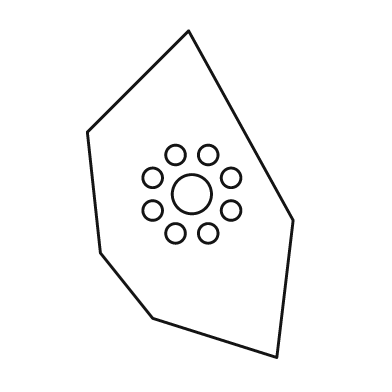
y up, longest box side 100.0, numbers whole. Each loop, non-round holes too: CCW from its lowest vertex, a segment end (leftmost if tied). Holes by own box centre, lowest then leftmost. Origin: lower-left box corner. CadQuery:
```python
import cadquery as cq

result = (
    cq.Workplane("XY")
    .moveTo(58.0, 0.0)
    .lineTo(63.0, 42.0)
    .lineTo(31.0, 100.0)
    .lineTo(0.0, 69.0)
    .lineTo(4.0, 32.0)
    .lineTo(20.0, 12.0)
    .close()
    .moveTo(27.0, 38.0)
    .circle(3.0)
    .moveTo(37.0, 38.0)
    .circle(3.0)
    .moveTo(20.0, 45.0)
    .circle(3.0)
    .moveTo(44.0, 45.0)
    .circle(3.0)
    .moveTo(32.0, 50.0)
    .circle(6.0)
    .moveTo(20.0, 55.0)
    .circle(3.0)
    .moveTo(44.0, 55.0)
    .circle(3.0)
    .moveTo(27.0, 62.0)
    .circle(3.0)
    .moveTo(37.0, 62.0)
    .circle(3.0)
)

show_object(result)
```